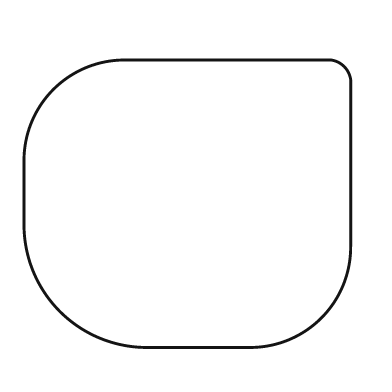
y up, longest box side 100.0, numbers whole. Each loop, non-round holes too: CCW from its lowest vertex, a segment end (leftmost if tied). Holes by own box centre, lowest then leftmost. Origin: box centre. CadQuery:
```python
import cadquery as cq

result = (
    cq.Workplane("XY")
    .moveTo(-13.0, -44.0)
    .lineTo(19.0, -44.0)
    .threePointArc((41.0, -35.0), (50.0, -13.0))
    .lineTo(50.0, 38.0)
    .threePointArc((48.0, 42.0), (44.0, 44.0))
    .lineTo(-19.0, 44.0)
    .threePointArc((-41.0, 35.0), (-50.0, 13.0))
    .lineTo(-50.0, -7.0)
    .threePointArc((-39.0, -33.0), (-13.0, -44.0))
    .close()
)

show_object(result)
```